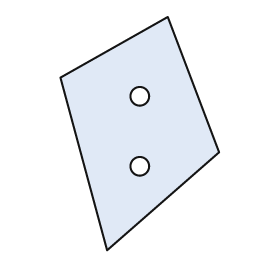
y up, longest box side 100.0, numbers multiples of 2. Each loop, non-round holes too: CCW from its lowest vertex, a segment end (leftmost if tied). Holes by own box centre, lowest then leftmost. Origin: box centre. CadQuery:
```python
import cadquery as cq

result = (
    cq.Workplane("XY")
    .moveTo(-14.0, -50.0)
    .lineTo(34.0, -8.0)
    .lineTo(12.0, 50.0)
    .lineTo(-34.0, 24.0)
    .close()
    .moveTo(0.0, -14.0)
    .circle(4.0)
    .moveTo(0.0, 16.0)
    .circle(4.0)
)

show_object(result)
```